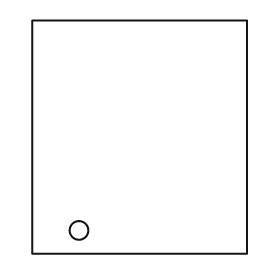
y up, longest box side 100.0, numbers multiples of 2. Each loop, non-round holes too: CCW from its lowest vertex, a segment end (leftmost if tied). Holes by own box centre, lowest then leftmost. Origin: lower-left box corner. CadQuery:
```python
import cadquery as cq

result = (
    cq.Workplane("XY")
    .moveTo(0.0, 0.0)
    .lineTo(92.0, 0.0)
    .lineTo(92.0, 100.0)
    .lineTo(0.0, 100.0)
    .close()
    .moveTo(20.0, 10.0)
    .circle(4.0)
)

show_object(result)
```